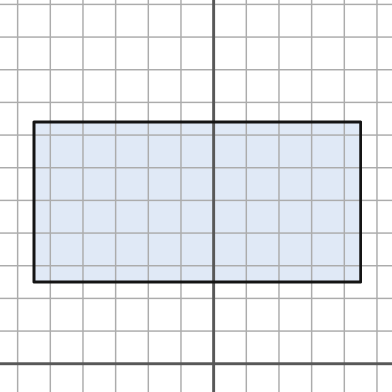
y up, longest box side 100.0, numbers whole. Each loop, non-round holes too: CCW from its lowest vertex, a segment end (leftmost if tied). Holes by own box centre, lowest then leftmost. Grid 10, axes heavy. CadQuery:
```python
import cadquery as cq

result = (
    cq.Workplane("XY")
    .moveTo(-55.0, 25.0)
    .lineTo(45.0, 25.0)
    .lineTo(45.0, 74.0)
    .lineTo(-55.0, 74.0)
    .close()
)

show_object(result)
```